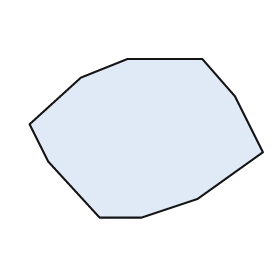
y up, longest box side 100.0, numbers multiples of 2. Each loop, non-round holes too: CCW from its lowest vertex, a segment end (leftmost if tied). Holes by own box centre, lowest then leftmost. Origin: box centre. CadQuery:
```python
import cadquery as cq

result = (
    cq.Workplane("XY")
    .moveTo(-20.0, -34.0)
    .lineTo(-2.0, -34.0)
    .lineTo(22.0, -26.0)
    .lineTo(50.0, -6.0)
    .lineTo(38.0, 18.0)
    .lineTo(24.0, 34.0)
    .lineTo(-8.0, 34.0)
    .lineTo(-28.0, 26.0)
    .lineTo(-50.0, 6.0)
    .lineTo(-42.0, -10.0)
    .close()
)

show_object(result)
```